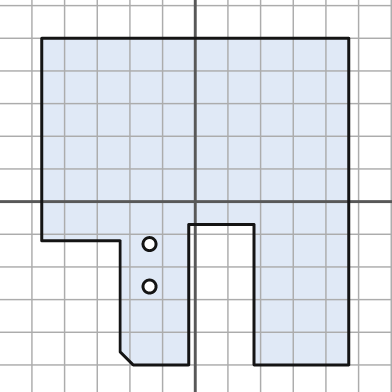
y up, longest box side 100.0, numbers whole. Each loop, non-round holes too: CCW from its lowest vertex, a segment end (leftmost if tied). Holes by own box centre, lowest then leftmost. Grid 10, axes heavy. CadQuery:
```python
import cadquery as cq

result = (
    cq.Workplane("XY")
    .moveTo(-19.0, -50.0)
    .lineTo(-2.0, -50.0)
    .lineTo(-2.0, -7.0)
    .lineTo(18.0, -7.0)
    .lineTo(18.0, -50.0)
    .lineTo(47.0, -50.0)
    .lineTo(47.0, 50.0)
    .lineTo(-47.0, 50.0)
    .lineTo(-47.0, -12.0)
    .lineTo(-23.0, -12.0)
    .lineTo(-23.0, -46.0)
    .close()
    .moveTo(-14.0, -26.0)
    .circle(2.0)
    .moveTo(-14.0, -13.0)
    .circle(2.0)
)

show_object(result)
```